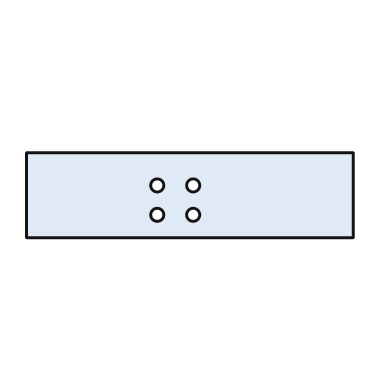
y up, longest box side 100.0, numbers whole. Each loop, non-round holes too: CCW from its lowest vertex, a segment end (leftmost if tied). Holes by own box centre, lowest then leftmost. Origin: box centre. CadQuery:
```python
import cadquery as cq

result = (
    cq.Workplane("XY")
    .moveTo(-50.0, -13.0)
    .lineTo(50.0, -13.0)
    .lineTo(50.0, 13.0)
    .lineTo(-50.0, 13.0)
    .close()
    .moveTo(-10.0, -6.0)
    .circle(2.0)
    .moveTo(1.0, -6.0)
    .circle(2.0)
    .moveTo(-10.0, 3.0)
    .circle(2.0)
    .moveTo(1.0, 3.0)
    .circle(2.0)
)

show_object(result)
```